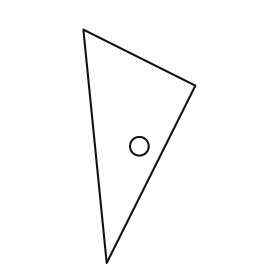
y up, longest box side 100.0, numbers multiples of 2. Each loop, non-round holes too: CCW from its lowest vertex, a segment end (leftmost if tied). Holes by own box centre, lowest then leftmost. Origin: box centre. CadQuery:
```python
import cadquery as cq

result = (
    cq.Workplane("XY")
    .moveTo(-14.0, -50.0)
    .lineTo(24.0, 26.0)
    .lineTo(-24.0, 50.0)
    .close()
    .moveTo(0.0, 0.0)
    .circle(4.0)
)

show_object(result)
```